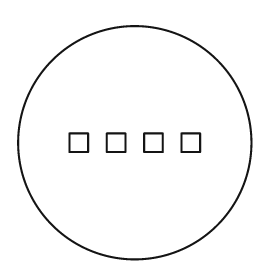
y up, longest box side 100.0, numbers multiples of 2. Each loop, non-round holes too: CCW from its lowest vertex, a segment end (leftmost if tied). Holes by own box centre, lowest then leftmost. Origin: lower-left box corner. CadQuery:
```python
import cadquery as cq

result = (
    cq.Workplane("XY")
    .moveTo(50.0, 50.0)
    .circle(50.0)
    .moveTo(22.0, 46.0)
    .lineTo(30.0, 46.0)
    .lineTo(30.0, 54.0)
    .lineTo(22.0, 54.0)
    .close()
    .moveTo(38.0, 46.0)
    .lineTo(46.0, 46.0)
    .lineTo(46.0, 54.0)
    .lineTo(38.0, 54.0)
    .close()
    .moveTo(54.0, 46.0)
    .lineTo(62.0, 46.0)
    .lineTo(62.0, 54.0)
    .lineTo(54.0, 54.0)
    .close()
    .moveTo(70.0, 46.0)
    .lineTo(78.0, 46.0)
    .lineTo(78.0, 54.0)
    .lineTo(70.0, 54.0)
    .close()
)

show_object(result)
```